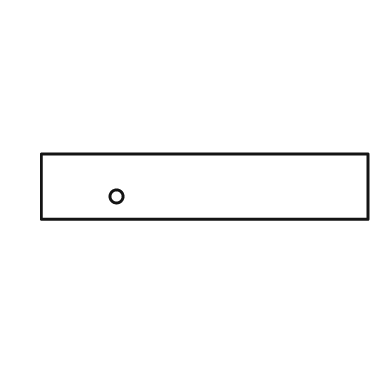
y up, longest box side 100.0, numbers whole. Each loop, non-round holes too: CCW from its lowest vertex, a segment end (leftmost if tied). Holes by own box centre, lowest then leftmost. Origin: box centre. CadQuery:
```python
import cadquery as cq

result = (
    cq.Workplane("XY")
    .moveTo(-50.0, -10.0)
    .lineTo(50.0, -10.0)
    .lineTo(50.0, 10.0)
    .lineTo(-50.0, 10.0)
    .close()
    .moveTo(-27.0, -3.0)
    .circle(2.0)
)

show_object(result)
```